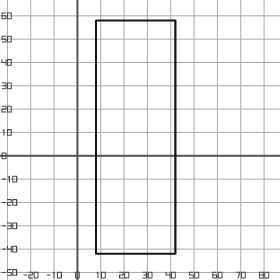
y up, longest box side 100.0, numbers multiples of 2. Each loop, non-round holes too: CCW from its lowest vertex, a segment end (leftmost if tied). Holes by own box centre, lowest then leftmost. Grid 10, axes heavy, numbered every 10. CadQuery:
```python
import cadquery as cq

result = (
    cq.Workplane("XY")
    .moveTo(8.0, -42.0)
    .lineTo(42.0, -42.0)
    .lineTo(42.0, 58.0)
    .lineTo(8.0, 58.0)
    .close()
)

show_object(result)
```